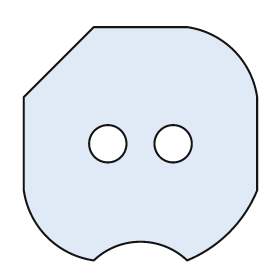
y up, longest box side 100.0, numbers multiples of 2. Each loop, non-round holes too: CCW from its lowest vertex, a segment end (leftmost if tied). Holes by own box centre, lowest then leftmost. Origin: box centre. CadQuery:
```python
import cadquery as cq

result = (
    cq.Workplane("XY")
    .moveTo(-20.0, -50.0)
    .threePointArc((0.0, -42.0), (20.0, -50.0))
    .threePointArc((38.0, -38.0), (50.0, -20.0))
    .lineTo(50.0, 20.0)
    .threePointArc((40.0, 40.0), (20.0, 50.0))
    .lineTo(-20.0, 50.0)
    .lineTo(-50.0, 20.0)
    .lineTo(-50.0, -20.0)
    .threePointArc((-40.0, -40.0), (-20.0, -50.0))
    .close()
    .moveTo(-14.0, 0.0)
    .circle(8.0)
    .moveTo(14.0, 0.0)
    .circle(8.0)
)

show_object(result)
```